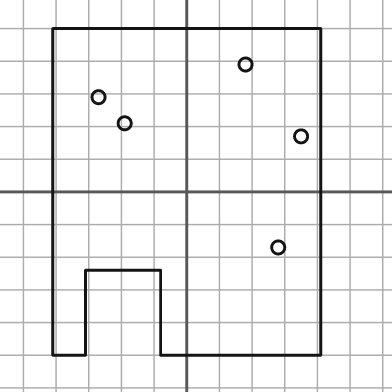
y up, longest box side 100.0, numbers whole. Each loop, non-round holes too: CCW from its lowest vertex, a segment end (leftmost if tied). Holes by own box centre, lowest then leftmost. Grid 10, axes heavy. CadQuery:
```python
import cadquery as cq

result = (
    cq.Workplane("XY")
    .moveTo(-41.0, -50.0)
    .lineTo(-31.0, -50.0)
    .lineTo(-31.0, -24.0)
    .lineTo(-8.0, -24.0)
    .lineTo(-8.0, -50.0)
    .lineTo(41.0, -50.0)
    .lineTo(41.0, 50.0)
    .lineTo(-41.0, 50.0)
    .close()
    .moveTo(28.0, -17.0)
    .circle(2.0)
    .moveTo(35.0, 17.0)
    .circle(2.0)
    .moveTo(-19.0, 21.0)
    .circle(2.0)
    .moveTo(-27.0, 29.0)
    .circle(2.0)
    .moveTo(18.0, 39.0)
    .circle(2.0)
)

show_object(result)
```